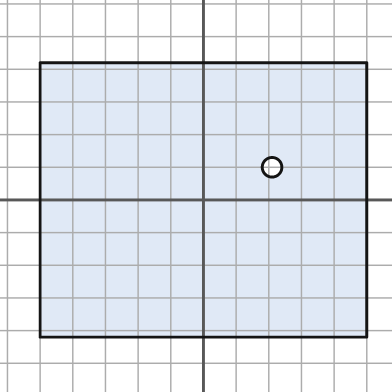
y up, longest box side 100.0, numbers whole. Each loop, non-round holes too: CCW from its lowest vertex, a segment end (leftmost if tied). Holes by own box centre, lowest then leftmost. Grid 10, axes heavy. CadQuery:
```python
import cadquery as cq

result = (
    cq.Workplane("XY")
    .moveTo(-50.0, -42.0)
    .lineTo(50.0, -42.0)
    .lineTo(50.0, 42.0)
    .lineTo(-50.0, 42.0)
    .close()
    .moveTo(21.0, 10.0)
    .circle(3.0)
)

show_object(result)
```